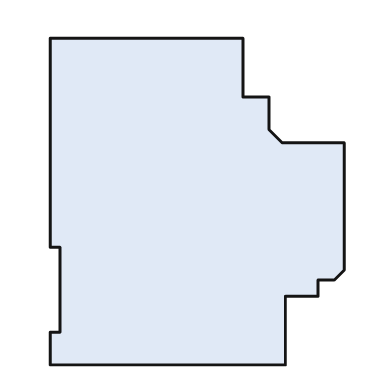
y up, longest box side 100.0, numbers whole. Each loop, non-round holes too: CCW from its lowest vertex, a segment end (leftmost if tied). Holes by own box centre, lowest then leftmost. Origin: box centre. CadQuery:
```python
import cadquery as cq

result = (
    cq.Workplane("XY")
    .moveTo(-45.0, -50.0)
    .lineTo(27.0, -50.0)
    .lineTo(27.0, -29.0)
    .lineTo(37.0, -29.0)
    .lineTo(37.0, -24.0)
    .lineTo(42.0, -24.0)
    .lineTo(45.0, -21.0)
    .lineTo(45.0, 18.0)
    .lineTo(26.0, 18.0)
    .lineTo(22.0, 22.0)
    .lineTo(22.0, 32.0)
    .lineTo(14.0, 32.0)
    .lineTo(14.0, 50.0)
    .lineTo(-45.0, 50.0)
    .lineTo(-45.0, -14.0)
    .lineTo(-42.0, -14.0)
    .lineTo(-42.0, -40.0)
    .lineTo(-45.0, -40.0)
    .close()
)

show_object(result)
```